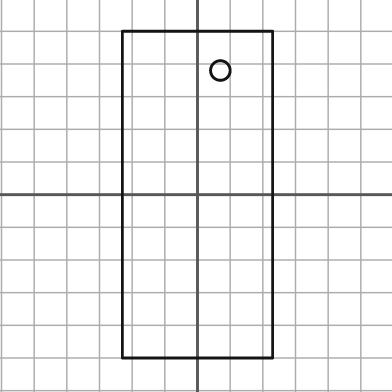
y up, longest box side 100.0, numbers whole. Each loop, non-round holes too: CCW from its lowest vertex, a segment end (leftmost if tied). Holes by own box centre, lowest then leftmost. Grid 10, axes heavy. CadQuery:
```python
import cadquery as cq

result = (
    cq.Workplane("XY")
    .moveTo(-23.0, -50.0)
    .lineTo(23.0, -50.0)
    .lineTo(23.0, 50.0)
    .lineTo(-23.0, 50.0)
    .close()
    .moveTo(7.0, 38.0)
    .circle(3.0)
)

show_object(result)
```